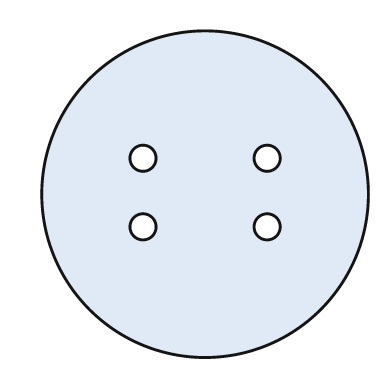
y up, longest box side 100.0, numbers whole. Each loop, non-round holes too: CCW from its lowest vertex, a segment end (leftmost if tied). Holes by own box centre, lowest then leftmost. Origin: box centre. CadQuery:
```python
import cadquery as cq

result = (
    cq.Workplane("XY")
    .moveTo(0.0, 0.0)
    .circle(50.0)
    .moveTo(-19.0, -10.0)
    .circle(4.0)
    .moveTo(19.0, -10.0)
    .circle(4.0)
    .moveTo(-19.0, 11.0)
    .circle(4.0)
    .moveTo(19.0, 11.0)
    .circle(4.0)
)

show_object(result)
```